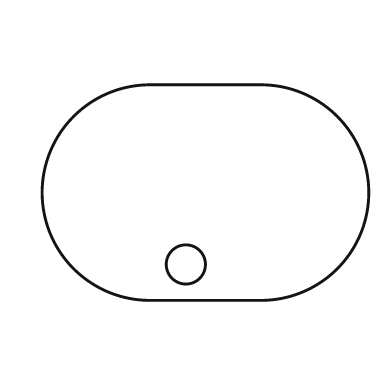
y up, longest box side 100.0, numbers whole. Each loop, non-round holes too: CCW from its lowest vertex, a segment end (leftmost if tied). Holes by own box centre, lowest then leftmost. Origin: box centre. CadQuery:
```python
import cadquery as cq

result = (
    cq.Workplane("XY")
    .moveTo(-17.0, -33.0)
    .lineTo(17.0, -33.0)
    .threePointArc((50.0, 0.0), (17.0, 33.0))
    .lineTo(-17.0, 33.0)
    .threePointArc((-50.0, 0.0), (-17.0, -33.0))
    .close()
    .moveTo(-6.0, -22.0)
    .circle(6.0)
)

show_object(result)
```